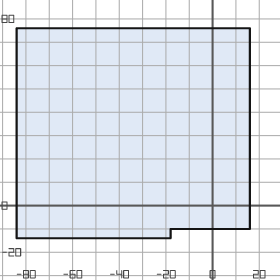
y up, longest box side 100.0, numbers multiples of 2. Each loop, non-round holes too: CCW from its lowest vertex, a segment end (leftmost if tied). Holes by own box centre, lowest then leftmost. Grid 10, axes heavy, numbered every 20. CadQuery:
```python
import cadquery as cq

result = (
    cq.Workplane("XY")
    .moveTo(-84.0, -14.0)
    .lineTo(-18.0, -14.0)
    .lineTo(-18.0, -10.0)
    .lineTo(16.0, -10.0)
    .lineTo(16.0, 76.0)
    .lineTo(-84.0, 76.0)
    .close()
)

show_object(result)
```